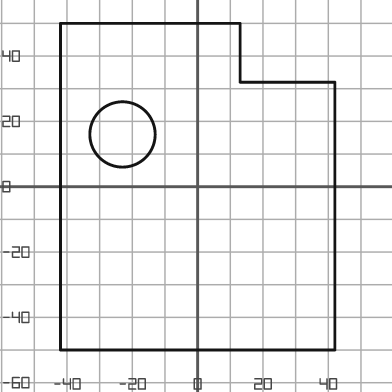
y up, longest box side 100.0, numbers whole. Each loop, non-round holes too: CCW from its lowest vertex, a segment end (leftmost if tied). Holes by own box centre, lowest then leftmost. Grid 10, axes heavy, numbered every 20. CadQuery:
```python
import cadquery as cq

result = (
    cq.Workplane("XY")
    .moveTo(-42.0, -50.0)
    .lineTo(42.0, -50.0)
    .lineTo(42.0, 32.0)
    .lineTo(13.0, 32.0)
    .lineTo(13.0, 50.0)
    .lineTo(-42.0, 50.0)
    .close()
    .moveTo(-23.0, 16.0)
    .circle(10.0)
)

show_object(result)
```